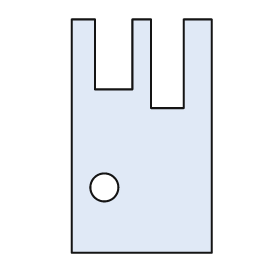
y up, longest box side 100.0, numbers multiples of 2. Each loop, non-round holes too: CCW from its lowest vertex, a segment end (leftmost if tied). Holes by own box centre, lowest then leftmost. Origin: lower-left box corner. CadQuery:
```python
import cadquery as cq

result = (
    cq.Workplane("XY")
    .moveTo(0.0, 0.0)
    .lineTo(60.0, 0.0)
    .lineTo(60.0, 100.0)
    .lineTo(48.0, 100.0)
    .lineTo(48.0, 62.0)
    .lineTo(34.0, 62.0)
    .lineTo(34.0, 100.0)
    .lineTo(26.0, 100.0)
    .lineTo(26.0, 70.0)
    .lineTo(10.0, 70.0)
    .lineTo(10.0, 100.0)
    .lineTo(0.0, 100.0)
    .close()
    .moveTo(14.0, 28.0)
    .circle(6.0)
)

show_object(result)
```